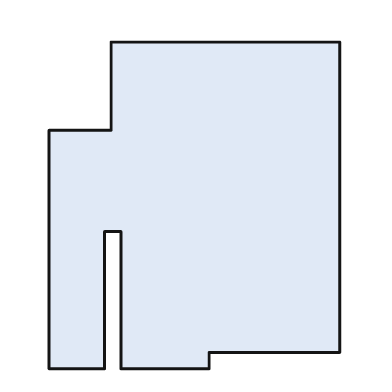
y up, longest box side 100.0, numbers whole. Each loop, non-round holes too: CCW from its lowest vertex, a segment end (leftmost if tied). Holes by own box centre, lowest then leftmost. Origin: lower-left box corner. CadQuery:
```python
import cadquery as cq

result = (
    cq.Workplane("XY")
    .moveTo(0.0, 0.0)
    .lineTo(17.0, 0.0)
    .lineTo(17.0, 42.0)
    .lineTo(22.0, 42.0)
    .lineTo(22.0, 0.0)
    .lineTo(49.0, 0.0)
    .lineTo(49.0, 5.0)
    .lineTo(89.0, 5.0)
    .lineTo(89.0, 100.0)
    .lineTo(19.0, 100.0)
    .lineTo(19.0, 73.0)
    .lineTo(0.0, 73.0)
    .close()
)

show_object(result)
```